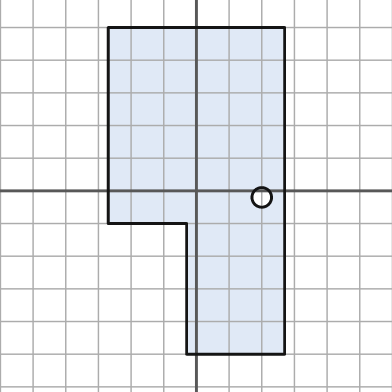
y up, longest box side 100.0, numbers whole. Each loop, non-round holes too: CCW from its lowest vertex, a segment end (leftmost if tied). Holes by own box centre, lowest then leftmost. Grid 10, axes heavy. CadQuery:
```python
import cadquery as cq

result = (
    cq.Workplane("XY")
    .moveTo(-3.0, -50.0)
    .lineTo(27.0, -50.0)
    .lineTo(27.0, 50.0)
    .lineTo(-27.0, 50.0)
    .lineTo(-27.0, -10.0)
    .lineTo(-3.0, -10.0)
    .close()
    .moveTo(20.0, -2.0)
    .circle(3.0)
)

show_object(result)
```